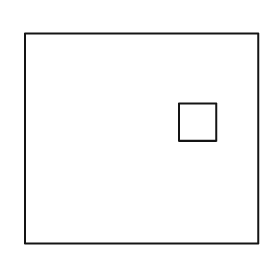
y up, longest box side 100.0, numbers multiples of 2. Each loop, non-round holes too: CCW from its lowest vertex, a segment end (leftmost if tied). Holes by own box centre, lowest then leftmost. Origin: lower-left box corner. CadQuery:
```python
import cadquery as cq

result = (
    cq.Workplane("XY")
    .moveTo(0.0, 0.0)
    .lineTo(100.0, 0.0)
    .lineTo(100.0, 90.0)
    .lineTo(0.0, 90.0)
    .close()
    .moveTo(66.0, 44.0)
    .lineTo(82.0, 44.0)
    .lineTo(82.0, 60.0)
    .lineTo(66.0, 60.0)
    .close()
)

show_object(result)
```